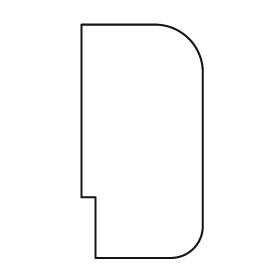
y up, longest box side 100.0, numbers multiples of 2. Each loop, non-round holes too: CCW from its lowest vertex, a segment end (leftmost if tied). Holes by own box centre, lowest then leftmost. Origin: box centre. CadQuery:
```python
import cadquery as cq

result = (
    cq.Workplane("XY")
    .moveTo(-20.0, -50.0)
    .lineTo(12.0, -50.0)
    .threePointArc((22.0, -46.0), (26.0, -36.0))
    .lineTo(26.0, 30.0)
    .threePointArc((20.0, 44.0), (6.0, 50.0))
    .lineTo(-26.0, 50.0)
    .lineTo(-26.0, -24.0)
    .lineTo(-20.0, -24.0)
    .close()
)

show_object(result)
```